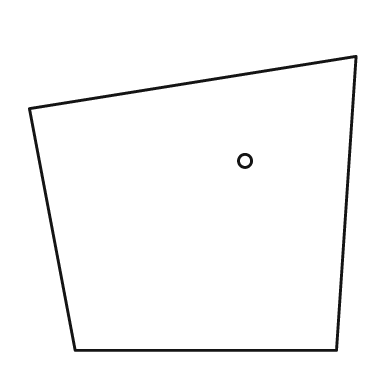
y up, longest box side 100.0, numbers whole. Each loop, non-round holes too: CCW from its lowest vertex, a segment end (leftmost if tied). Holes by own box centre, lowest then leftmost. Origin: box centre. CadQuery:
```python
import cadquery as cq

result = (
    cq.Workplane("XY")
    .moveTo(-36.0, -45.0)
    .lineTo(44.0, -45.0)
    .lineTo(50.0, 45.0)
    .lineTo(-50.0, 29.0)
    .close()
    .moveTo(16.0, 13.0)
    .circle(2.0)
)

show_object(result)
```